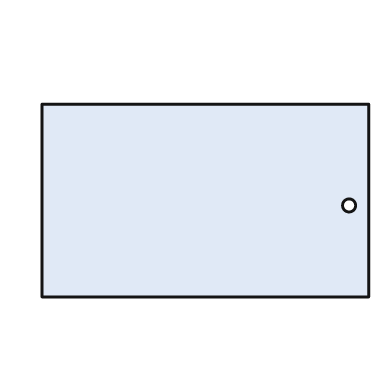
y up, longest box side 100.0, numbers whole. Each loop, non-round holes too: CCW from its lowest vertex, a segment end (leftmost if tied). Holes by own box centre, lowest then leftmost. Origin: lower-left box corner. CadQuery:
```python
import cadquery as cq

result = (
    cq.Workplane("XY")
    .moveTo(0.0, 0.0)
    .lineTo(100.0, 0.0)
    .lineTo(100.0, 59.0)
    .lineTo(0.0, 59.0)
    .close()
    .moveTo(94.0, 28.0)
    .circle(2.0)
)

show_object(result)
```